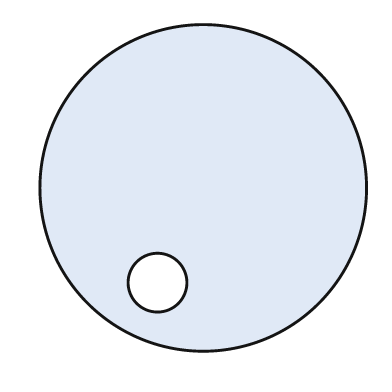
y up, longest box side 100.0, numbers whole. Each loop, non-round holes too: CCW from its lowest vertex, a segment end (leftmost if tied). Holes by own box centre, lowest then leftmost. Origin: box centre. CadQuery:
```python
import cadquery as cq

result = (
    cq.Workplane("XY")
    .moveTo(0.0, 0.0)
    .circle(50.0)
    .moveTo(-14.0, -29.0)
    .circle(9.0)
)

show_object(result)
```